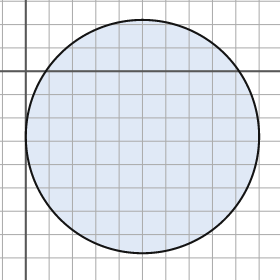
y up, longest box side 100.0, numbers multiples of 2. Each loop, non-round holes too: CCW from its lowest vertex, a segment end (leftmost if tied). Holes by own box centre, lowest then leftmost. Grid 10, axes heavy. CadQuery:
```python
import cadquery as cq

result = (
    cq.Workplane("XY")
    .moveTo(50.0, -28.0)
    .circle(50.0)
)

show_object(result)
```